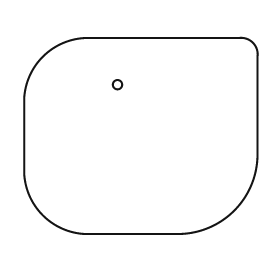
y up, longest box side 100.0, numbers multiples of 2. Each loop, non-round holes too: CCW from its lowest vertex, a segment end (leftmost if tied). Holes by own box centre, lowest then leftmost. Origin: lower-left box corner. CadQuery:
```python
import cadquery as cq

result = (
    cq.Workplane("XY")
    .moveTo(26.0, 0.0)
    .lineTo(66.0, 0.0)
    .threePointArc((90.0, 10.0), (100.0, 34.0))
    .lineTo(100.0, 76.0)
    .threePointArc((98.0, 82.0), (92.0, 84.0))
    .lineTo(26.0, 84.0)
    .threePointArc((8.0, 76.0), (0.0, 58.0))
    .lineTo(0.0, 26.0)
    .threePointArc((8.0, 8.0), (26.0, 0.0))
    .close()
    .moveTo(40.0, 64.0)
    .circle(2.0)
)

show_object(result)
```